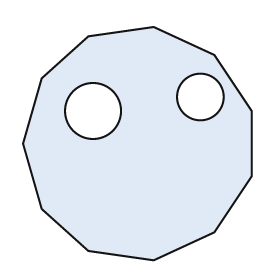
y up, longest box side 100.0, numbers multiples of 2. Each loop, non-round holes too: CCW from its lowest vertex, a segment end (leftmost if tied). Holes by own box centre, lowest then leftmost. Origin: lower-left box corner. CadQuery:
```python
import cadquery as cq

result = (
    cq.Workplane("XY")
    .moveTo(56.0, 0.0)
    .lineTo(82.0, 12.0)
    .lineTo(98.0, 36.0)
    .lineTo(98.0, 64.0)
    .lineTo(82.0, 88.0)
    .lineTo(56.0, 100.0)
    .lineTo(28.0, 96.0)
    .lineTo(8.0, 78.0)
    .lineTo(0.0, 50.0)
    .lineTo(8.0, 22.0)
    .lineTo(28.0, 4.0)
    .close()
    .moveTo(30.0, 64.0)
    .circle(12.0)
    .moveTo(76.0, 70.0)
    .circle(10.0)
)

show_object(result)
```